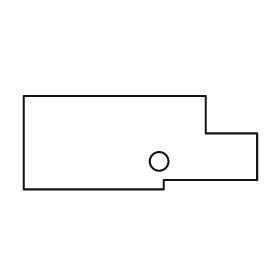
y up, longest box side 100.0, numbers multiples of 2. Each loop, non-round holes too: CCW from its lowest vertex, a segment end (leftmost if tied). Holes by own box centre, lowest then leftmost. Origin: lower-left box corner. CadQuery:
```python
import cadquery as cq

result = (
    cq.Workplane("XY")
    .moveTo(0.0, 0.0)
    .lineTo(60.0, 0.0)
    .lineTo(60.0, 4.0)
    .lineTo(100.0, 4.0)
    .lineTo(100.0, 24.0)
    .lineTo(78.0, 24.0)
    .lineTo(78.0, 40.0)
    .lineTo(0.0, 40.0)
    .close()
    .moveTo(58.0, 12.0)
    .circle(4.0)
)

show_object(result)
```